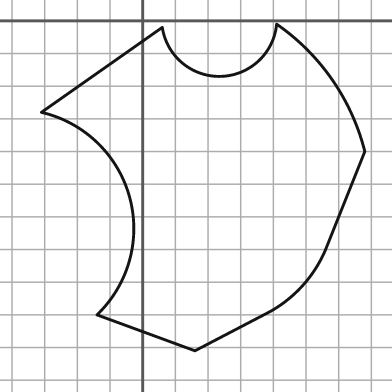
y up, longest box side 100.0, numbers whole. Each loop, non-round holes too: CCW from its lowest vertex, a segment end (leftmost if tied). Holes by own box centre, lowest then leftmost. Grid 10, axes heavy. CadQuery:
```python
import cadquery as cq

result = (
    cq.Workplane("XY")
    .moveTo(16.0, -101.0)
    .lineTo(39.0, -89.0)
    .threePointArc((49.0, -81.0), (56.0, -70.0))
    .lineTo(68.0, -40.0)
    .threePointArc((58.0, -18.0), (41.0, -1.0))
    .threePointArc((24.0, -17.0), (6.0, -2.0))
    .lineTo(-31.0, -28.0)
    .threePointArc((-4.0, -54.0), (-14.0, -90.0))
    .close()
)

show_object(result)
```